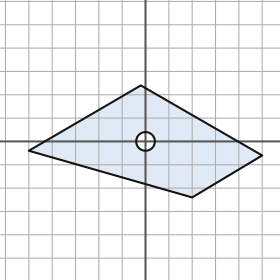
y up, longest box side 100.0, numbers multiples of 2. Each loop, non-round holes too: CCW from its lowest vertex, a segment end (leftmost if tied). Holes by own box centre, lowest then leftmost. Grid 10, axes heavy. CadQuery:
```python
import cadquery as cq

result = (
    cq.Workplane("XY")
    .moveTo(20.0, -24.0)
    .lineTo(50.0, -6.0)
    .lineTo(-2.0, 24.0)
    .lineTo(-50.0, -4.0)
    .close()
    .moveTo(0.0, 0.0)
    .circle(4.0)
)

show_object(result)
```